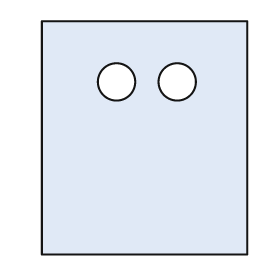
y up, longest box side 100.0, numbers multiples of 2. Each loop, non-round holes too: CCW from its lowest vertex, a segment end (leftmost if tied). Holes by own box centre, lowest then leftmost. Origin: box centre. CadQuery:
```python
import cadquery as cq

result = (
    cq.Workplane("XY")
    .moveTo(-44.0, -50.0)
    .lineTo(44.0, -50.0)
    .lineTo(44.0, 50.0)
    .lineTo(-44.0, 50.0)
    .close()
    .moveTo(-12.0, 24.0)
    .circle(8.0)
    .moveTo(14.0, 24.0)
    .circle(8.0)
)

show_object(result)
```